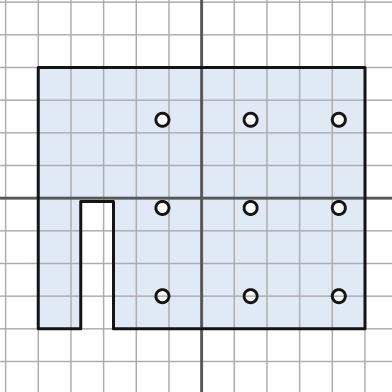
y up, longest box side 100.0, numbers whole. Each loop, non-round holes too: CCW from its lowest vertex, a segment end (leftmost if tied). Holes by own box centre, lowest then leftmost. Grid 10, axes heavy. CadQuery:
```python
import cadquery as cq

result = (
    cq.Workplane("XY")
    .moveTo(-50.0, -40.0)
    .lineTo(-37.0, -40.0)
    .lineTo(-37.0, -1.0)
    .lineTo(-27.0, -1.0)
    .lineTo(-27.0, -40.0)
    .lineTo(50.0, -40.0)
    .lineTo(50.0, 40.0)
    .lineTo(-50.0, 40.0)
    .close()
    .moveTo(-12.0, -30.0)
    .circle(2.0)
    .moveTo(15.0, -30.0)
    .circle(2.0)
    .moveTo(42.0, -30.0)
    .circle(2.0)
    .moveTo(-12.0, -3.0)
    .circle(2.0)
    .moveTo(15.0, -3.0)
    .circle(2.0)
    .moveTo(42.0, -3.0)
    .circle(2.0)
    .moveTo(-12.0, 24.0)
    .circle(2.0)
    .moveTo(15.0, 24.0)
    .circle(2.0)
    .moveTo(42.0, 24.0)
    .circle(2.0)
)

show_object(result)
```